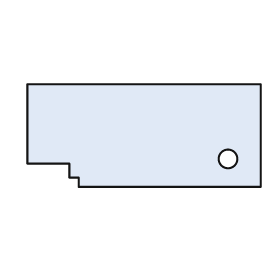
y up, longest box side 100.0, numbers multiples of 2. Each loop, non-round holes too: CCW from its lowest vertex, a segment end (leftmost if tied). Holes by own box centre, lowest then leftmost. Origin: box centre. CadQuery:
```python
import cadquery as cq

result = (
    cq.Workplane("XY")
    .moveTo(-28.0, -22.0)
    .lineTo(50.0, -22.0)
    .lineTo(50.0, 22.0)
    .lineTo(-50.0, 22.0)
    .lineTo(-50.0, -12.0)
    .lineTo(-32.0, -12.0)
    .lineTo(-32.0, -18.0)
    .lineTo(-28.0, -18.0)
    .close()
    .moveTo(36.0, -10.0)
    .circle(4.0)
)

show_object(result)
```